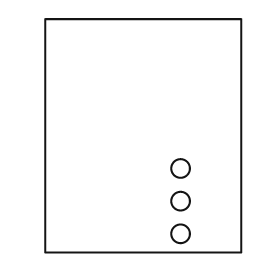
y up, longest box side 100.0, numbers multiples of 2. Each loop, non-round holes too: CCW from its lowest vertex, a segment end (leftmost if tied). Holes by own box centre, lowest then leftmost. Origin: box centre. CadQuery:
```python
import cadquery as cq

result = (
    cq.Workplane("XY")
    .moveTo(-42.0, -50.0)
    .lineTo(42.0, -50.0)
    .lineTo(42.0, 50.0)
    .lineTo(-42.0, 50.0)
    .close()
    .moveTo(16.0, -42.0)
    .circle(4.0)
    .moveTo(16.0, -28.0)
    .circle(4.0)
    .moveTo(16.0, -14.0)
    .circle(4.0)
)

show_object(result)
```